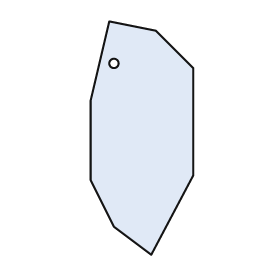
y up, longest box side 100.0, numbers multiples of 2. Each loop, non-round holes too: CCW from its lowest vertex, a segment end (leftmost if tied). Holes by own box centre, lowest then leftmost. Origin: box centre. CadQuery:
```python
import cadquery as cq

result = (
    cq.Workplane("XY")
    .moveTo(4.0, -50.0)
    .lineTo(22.0, -16.0)
    .lineTo(22.0, 30.0)
    .lineTo(6.0, 46.0)
    .lineTo(-14.0, 50.0)
    .lineTo(-22.0, 16.0)
    .lineTo(-22.0, -18.0)
    .lineTo(-12.0, -38.0)
    .close()
    .moveTo(-12.0, 32.0)
    .circle(2.0)
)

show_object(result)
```